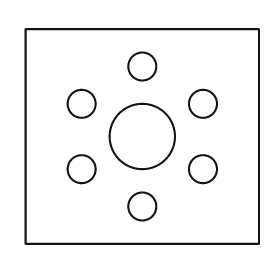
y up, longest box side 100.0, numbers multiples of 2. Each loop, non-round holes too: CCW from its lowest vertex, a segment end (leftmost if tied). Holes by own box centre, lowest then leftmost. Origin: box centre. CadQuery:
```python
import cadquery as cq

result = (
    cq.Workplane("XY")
    .moveTo(-50.0, -46.0)
    .lineTo(50.0, -46.0)
    .lineTo(50.0, 46.0)
    .lineTo(-50.0, 46.0)
    .close()
    .moveTo(0.0, -30.0)
    .circle(6.0)
    .moveTo(-26.0, -14.0)
    .circle(6.0)
    .moveTo(26.0, -14.0)
    .circle(6.0)
    .moveTo(0.0, 0.0)
    .circle(14.0)
    .moveTo(-26.0, 14.0)
    .circle(6.0)
    .moveTo(26.0, 14.0)
    .circle(6.0)
    .moveTo(0.0, 30.0)
    .circle(6.0)
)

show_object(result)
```